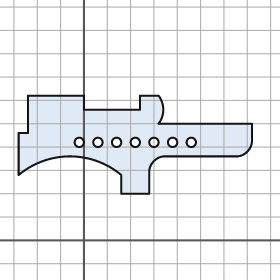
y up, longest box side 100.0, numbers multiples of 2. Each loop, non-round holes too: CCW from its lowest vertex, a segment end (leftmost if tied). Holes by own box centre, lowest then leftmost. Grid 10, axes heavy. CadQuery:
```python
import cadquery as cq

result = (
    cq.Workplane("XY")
    .moveTo(16.0, 20.0)
    .lineTo(28.0, 20.0)
    .lineTo(28.0, 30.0)
    .threePointArc((30.0, 34.0), (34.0, 36.0))
    .lineTo(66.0, 36.0)
    .threePointArc((70.0, 38.0), (72.0, 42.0))
    .lineTo(72.0, 50.0)
    .lineTo(32.0, 50.0)
    .threePointArc((34.0, 56.0), (32.0, 62.0))
    .lineTo(24.0, 62.0)
    .lineTo(24.0, 56.0)
    .lineTo(0.0, 56.0)
    .lineTo(0.0, 62.0)
    .lineTo(-24.0, 62.0)
    .lineTo(-24.0, 46.0)
    .lineTo(-28.0, 46.0)
    .lineTo(-28.0, 28.0)
    .threePointArc((-6.0, 36.0), (16.0, 28.0))
    .close()
    .moveTo(-2.0, 42.0)
    .circle(2.0)
    .moveTo(6.0, 42.0)
    .circle(2.0)
    .moveTo(14.0, 42.0)
    .circle(2.0)
    .moveTo(22.0, 42.0)
    .circle(2.0)
    .moveTo(30.0, 42.0)
    .circle(2.0)
    .moveTo(38.0, 42.0)
    .circle(2.0)
    .moveTo(46.0, 42.0)
    .circle(2.0)
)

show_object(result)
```